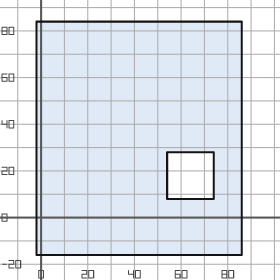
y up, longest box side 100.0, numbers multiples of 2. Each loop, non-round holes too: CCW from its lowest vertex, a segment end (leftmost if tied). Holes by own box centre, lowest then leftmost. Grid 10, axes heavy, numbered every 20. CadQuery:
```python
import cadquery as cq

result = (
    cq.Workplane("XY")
    .moveTo(-2.0, -16.0)
    .lineTo(86.0, -16.0)
    .lineTo(86.0, 84.0)
    .lineTo(-2.0, 84.0)
    .close()
    .moveTo(54.0, 8.0)
    .lineTo(74.0, 8.0)
    .lineTo(74.0, 28.0)
    .lineTo(54.0, 28.0)
    .close()
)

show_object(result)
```